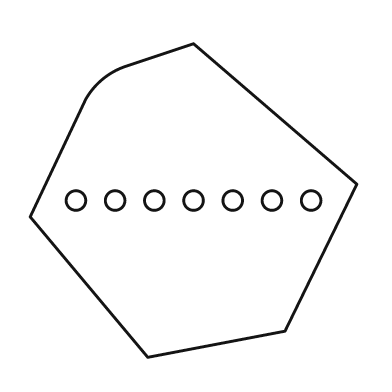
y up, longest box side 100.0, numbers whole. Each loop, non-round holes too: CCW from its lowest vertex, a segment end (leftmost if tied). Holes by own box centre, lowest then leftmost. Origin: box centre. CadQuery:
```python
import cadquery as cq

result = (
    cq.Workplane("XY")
    .moveTo(-14.0, -48.0)
    .lineTo(28.0, -40.0)
    .lineTo(50.0, 5.0)
    .lineTo(0.0, 48.0)
    .lineTo(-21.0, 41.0)
    .threePointArc((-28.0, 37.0), (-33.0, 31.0))
    .lineTo(-50.0, -5.0)
    .close()
    .moveTo(-36.0, 0.0)
    .circle(3.0)
    .moveTo(-24.0, 0.0)
    .circle(3.0)
    .moveTo(-12.0, 0.0)
    .circle(3.0)
    .moveTo(0.0, 0.0)
    .circle(3.0)
    .moveTo(12.0, 0.0)
    .circle(3.0)
    .moveTo(24.0, 0.0)
    .circle(3.0)
    .moveTo(36.0, 0.0)
    .circle(3.0)
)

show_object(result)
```